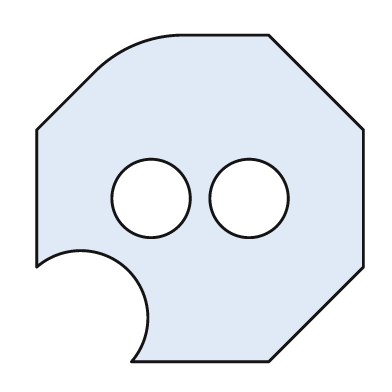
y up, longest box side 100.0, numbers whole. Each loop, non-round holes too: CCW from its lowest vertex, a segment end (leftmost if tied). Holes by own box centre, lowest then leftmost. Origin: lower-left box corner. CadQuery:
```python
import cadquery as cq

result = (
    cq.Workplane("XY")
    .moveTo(29.0, 0.0)
    .lineTo(71.0, 0.0)
    .lineTo(100.0, 29.0)
    .lineTo(100.0, 71.0)
    .lineTo(71.0, 100.0)
    .lineTo(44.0, 100.0)
    .threePointArc((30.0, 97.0), (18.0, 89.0))
    .lineTo(0.0, 71.0)
    .lineTo(0.0, 29.0)
    .threePointArc((28.0, 28.0), (29.0, 0.0))
    .close()
    .moveTo(35.0, 50.0)
    .circle(12.0)
    .moveTo(65.0, 50.0)
    .circle(12.0)
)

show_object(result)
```